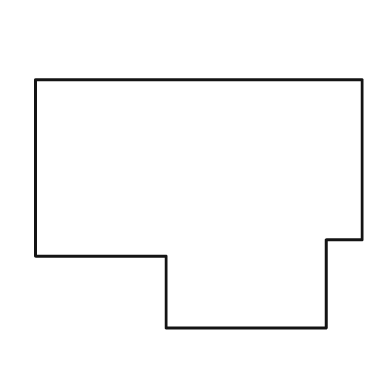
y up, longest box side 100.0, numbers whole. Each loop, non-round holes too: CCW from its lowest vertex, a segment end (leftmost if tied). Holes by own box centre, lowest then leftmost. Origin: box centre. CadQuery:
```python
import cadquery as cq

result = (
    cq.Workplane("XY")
    .moveTo(-10.0, -38.0)
    .lineTo(39.0, -38.0)
    .lineTo(39.0, -11.0)
    .lineTo(50.0, -11.0)
    .lineTo(50.0, 38.0)
    .lineTo(-50.0, 38.0)
    .lineTo(-50.0, -16.0)
    .lineTo(-10.0, -16.0)
    .close()
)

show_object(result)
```